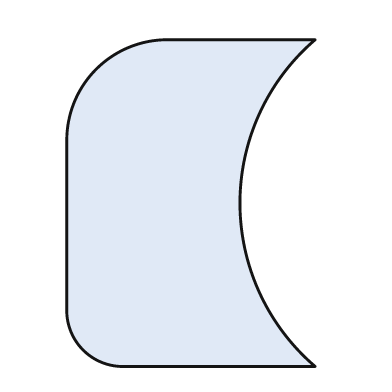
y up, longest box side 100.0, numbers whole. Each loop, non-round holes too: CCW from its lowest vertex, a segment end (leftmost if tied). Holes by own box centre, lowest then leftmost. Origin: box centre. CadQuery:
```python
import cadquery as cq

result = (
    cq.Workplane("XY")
    .moveTo(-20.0, -50.0)
    .lineTo(38.0, -50.0)
    .threePointArc((15.0, 0.0), (38.0, 50.0))
    .lineTo(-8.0, 50.0)
    .threePointArc((-29.0, 41.0), (-38.0, 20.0))
    .lineTo(-38.0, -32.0)
    .threePointArc((-33.0, -45.0), (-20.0, -50.0))
    .close()
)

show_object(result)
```